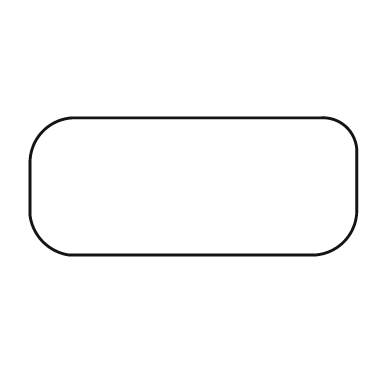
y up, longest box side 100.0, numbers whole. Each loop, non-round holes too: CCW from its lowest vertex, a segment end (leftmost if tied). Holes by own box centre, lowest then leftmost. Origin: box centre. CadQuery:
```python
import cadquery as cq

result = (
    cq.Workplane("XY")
    .moveTo(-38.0, -21.0)
    .lineTo(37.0, -21.0)
    .threePointArc((46.0, -17.0), (50.0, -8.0))
    .lineTo(50.0, 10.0)
    .threePointArc((47.0, 18.0), (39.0, 21.0))
    .lineTo(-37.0, 21.0)
    .threePointArc((-46.0, 17.0), (-50.0, 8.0))
    .lineTo(-50.0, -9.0)
    .threePointArc((-46.0, -17.0), (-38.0, -21.0))
    .close()
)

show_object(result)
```